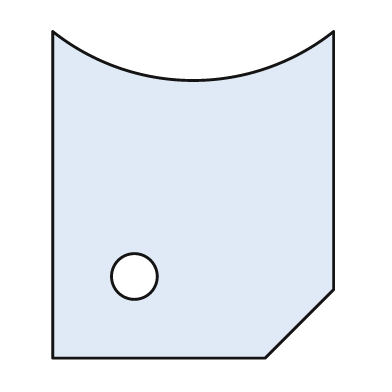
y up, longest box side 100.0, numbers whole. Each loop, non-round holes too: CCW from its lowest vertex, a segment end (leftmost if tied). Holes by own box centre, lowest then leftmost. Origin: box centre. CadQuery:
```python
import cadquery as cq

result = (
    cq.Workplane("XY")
    .moveTo(-43.0, -50.0)
    .lineTo(22.0, -50.0)
    .lineTo(43.0, -29.0)
    .lineTo(43.0, 50.0)
    .threePointArc((0.0, 35.0), (-43.0, 50.0))
    .close()
    .moveTo(-18.0, -25.0)
    .circle(7.0)
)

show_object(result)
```